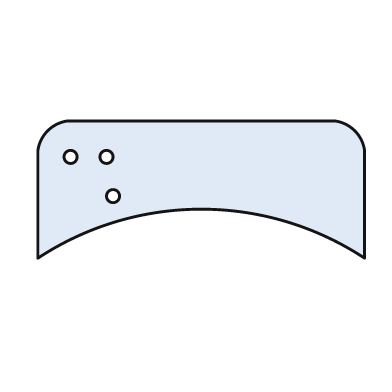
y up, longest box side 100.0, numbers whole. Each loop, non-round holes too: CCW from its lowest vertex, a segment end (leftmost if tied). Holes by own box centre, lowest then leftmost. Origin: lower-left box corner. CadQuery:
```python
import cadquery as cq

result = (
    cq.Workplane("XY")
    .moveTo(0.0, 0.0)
    .threePointArc((50.0, 15.0), (100.0, 0.0))
    .lineTo(100.0, 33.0)
    .threePointArc((97.0, 39.0), (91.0, 42.0))
    .lineTo(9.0, 42.0)
    .threePointArc((3.0, 39.0), (0.0, 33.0))
    .close()
    .moveTo(23.0, 19.0)
    .circle(2.0)
    .moveTo(10.0, 31.0)
    .circle(2.0)
    .moveTo(21.0, 31.0)
    .circle(2.0)
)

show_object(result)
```